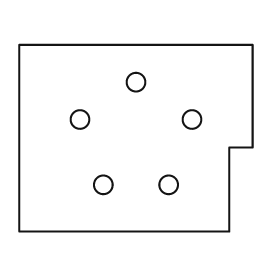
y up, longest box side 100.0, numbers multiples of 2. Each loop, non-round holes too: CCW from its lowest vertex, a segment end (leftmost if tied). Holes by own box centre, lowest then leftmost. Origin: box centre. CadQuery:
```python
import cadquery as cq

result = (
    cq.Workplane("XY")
    .moveTo(-50.0, -40.0)
    .lineTo(40.0, -40.0)
    .lineTo(40.0, -4.0)
    .lineTo(50.0, -4.0)
    .lineTo(50.0, 40.0)
    .lineTo(-50.0, 40.0)
    .close()
    .moveTo(-14.0, -20.0)
    .circle(4.0)
    .moveTo(14.0, -20.0)
    .circle(4.0)
    .moveTo(-24.0, 8.0)
    .circle(4.0)
    .moveTo(24.0, 8.0)
    .circle(4.0)
    .moveTo(0.0, 24.0)
    .circle(4.0)
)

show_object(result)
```